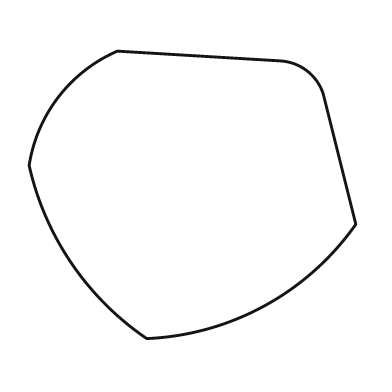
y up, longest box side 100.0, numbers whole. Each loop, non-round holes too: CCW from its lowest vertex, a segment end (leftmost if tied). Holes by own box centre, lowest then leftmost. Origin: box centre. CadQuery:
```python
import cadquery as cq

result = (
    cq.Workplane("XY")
    .moveTo(-14.0, -44.0)
    .threePointArc((22.0, -34.0), (50.0, -9.0))
    .lineTo(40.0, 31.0)
    .threePointArc((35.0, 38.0), (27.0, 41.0))
    .lineTo(-23.0, 44.0)
    .threePointArc((-41.0, 30.0), (-50.0, 9.0))
    .threePointArc((-37.0, -21.0), (-14.0, -44.0))
    .close()
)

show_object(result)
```